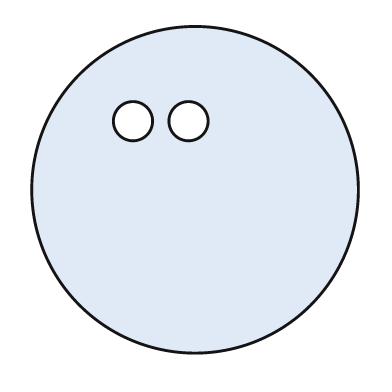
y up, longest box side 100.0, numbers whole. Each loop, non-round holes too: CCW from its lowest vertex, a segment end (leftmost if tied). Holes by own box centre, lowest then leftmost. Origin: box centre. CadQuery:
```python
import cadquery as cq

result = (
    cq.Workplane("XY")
    .moveTo(0.0, 0.0)
    .circle(50.0)
    .moveTo(-19.0, 21.0)
    .circle(6.0)
    .moveTo(-2.0, 21.0)
    .circle(6.0)
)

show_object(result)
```